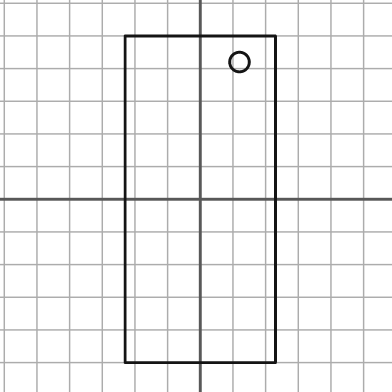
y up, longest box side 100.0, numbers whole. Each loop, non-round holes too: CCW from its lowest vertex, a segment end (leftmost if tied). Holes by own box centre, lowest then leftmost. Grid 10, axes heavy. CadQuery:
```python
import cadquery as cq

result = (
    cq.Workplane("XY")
    .moveTo(-23.0, -50.0)
    .lineTo(23.0, -50.0)
    .lineTo(23.0, 50.0)
    .lineTo(-23.0, 50.0)
    .close()
    .moveTo(12.0, 42.0)
    .circle(3.0)
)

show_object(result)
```